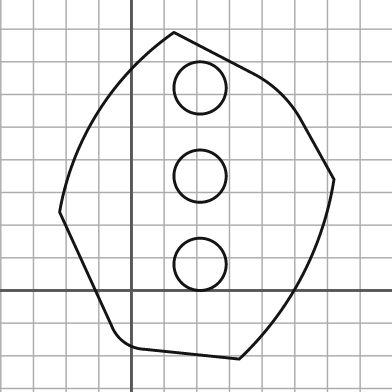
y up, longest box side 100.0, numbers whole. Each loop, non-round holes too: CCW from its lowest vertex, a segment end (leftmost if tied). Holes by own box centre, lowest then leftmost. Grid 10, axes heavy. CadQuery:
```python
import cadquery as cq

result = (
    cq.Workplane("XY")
    .moveTo(33.0, -21.0)
    .threePointArc((52.0, 4.0), (62.0, 34.0))
    .lineTo(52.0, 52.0)
    .threePointArc((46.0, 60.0), (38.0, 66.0))
    .lineTo(13.0, 79.0)
    .threePointArc((-10.0, 55.0), (-22.0, 24.0))
    .lineTo(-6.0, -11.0)
    .threePointArc((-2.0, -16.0), (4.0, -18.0))
    .close()
    .moveTo(21.0, 8.0)
    .circle(8.0)
    .moveTo(21.0, 35.0)
    .circle(8.0)
    .moveTo(21.0, 62.0)
    .circle(8.0)
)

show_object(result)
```